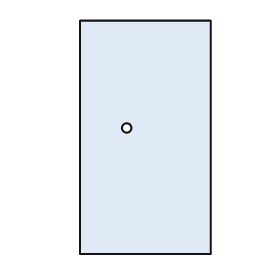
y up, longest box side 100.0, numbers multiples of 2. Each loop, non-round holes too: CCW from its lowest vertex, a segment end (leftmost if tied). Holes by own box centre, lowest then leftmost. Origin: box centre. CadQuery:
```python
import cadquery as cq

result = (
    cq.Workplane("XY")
    .moveTo(-28.0, -50.0)
    .lineTo(28.0, -50.0)
    .lineTo(28.0, 50.0)
    .lineTo(-28.0, 50.0)
    .close()
    .moveTo(-8.0, 4.0)
    .circle(2.0)
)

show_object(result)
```